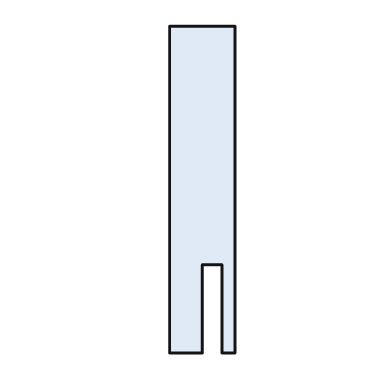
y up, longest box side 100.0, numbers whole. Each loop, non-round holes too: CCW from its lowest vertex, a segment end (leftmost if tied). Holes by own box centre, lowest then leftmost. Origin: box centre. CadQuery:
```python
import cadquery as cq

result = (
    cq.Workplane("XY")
    .moveTo(-10.0, -50.0)
    .lineTo(0.0, -50.0)
    .lineTo(0.0, -23.0)
    .lineTo(6.0, -23.0)
    .lineTo(6.0, -50.0)
    .lineTo(10.0, -50.0)
    .lineTo(10.0, 50.0)
    .lineTo(-10.0, 50.0)
    .close()
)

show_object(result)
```